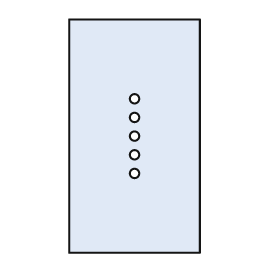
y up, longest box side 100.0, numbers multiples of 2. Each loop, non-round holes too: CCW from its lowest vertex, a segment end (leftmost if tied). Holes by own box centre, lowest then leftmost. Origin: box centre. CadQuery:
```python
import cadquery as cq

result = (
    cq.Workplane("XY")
    .moveTo(-28.0, -50.0)
    .lineTo(28.0, -50.0)
    .lineTo(28.0, 50.0)
    .lineTo(-28.0, 50.0)
    .close()
    .moveTo(0.0, -16.0)
    .circle(2.0)
    .moveTo(0.0, -8.0)
    .circle(2.0)
    .moveTo(0.0, 0.0)
    .circle(2.0)
    .moveTo(0.0, 8.0)
    .circle(2.0)
    .moveTo(0.0, 16.0)
    .circle(2.0)
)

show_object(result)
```